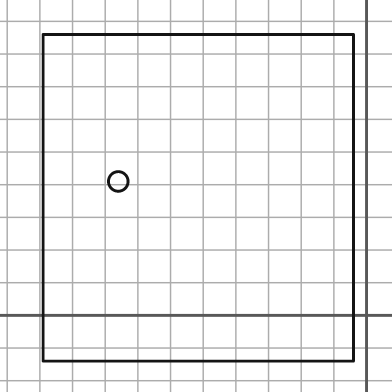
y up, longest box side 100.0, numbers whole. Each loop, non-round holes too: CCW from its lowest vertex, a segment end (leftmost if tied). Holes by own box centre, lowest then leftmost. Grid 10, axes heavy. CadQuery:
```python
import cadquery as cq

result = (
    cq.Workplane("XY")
    .moveTo(-99.0, -14.0)
    .lineTo(-4.0, -14.0)
    .lineTo(-4.0, 86.0)
    .lineTo(-99.0, 86.0)
    .close()
    .moveTo(-76.0, 41.0)
    .circle(3.0)
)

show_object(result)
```